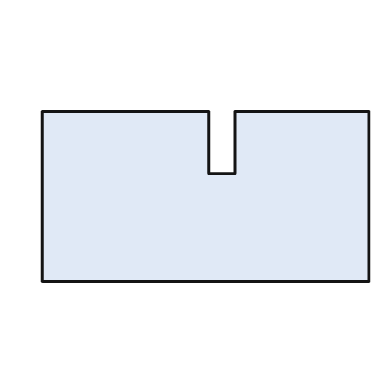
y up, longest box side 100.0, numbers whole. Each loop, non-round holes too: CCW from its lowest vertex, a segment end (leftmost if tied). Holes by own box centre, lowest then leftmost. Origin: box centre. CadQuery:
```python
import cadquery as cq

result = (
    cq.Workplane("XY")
    .moveTo(-50.0, -26.0)
    .lineTo(50.0, -26.0)
    .lineTo(50.0, 26.0)
    .lineTo(9.0, 26.0)
    .lineTo(9.0, 7.0)
    .lineTo(1.0, 7.0)
    .lineTo(1.0, 26.0)
    .lineTo(-50.0, 26.0)
    .close()
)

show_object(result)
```